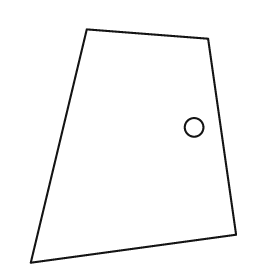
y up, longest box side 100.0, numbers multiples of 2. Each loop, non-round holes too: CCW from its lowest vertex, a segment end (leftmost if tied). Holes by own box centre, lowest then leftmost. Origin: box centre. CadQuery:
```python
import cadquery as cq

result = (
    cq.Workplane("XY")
    .moveTo(-44.0, -50.0)
    .lineTo(44.0, -38.0)
    .lineTo(32.0, 46.0)
    .lineTo(-20.0, 50.0)
    .close()
    .moveTo(26.0, 8.0)
    .circle(4.0)
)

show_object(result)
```